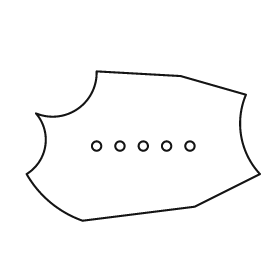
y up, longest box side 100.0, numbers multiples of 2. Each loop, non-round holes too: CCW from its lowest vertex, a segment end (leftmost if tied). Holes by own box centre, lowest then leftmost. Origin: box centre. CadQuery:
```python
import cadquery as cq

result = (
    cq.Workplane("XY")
    .moveTo(-26.0, -32.0)
    .lineTo(22.0, -26.0)
    .lineTo(50.0, -12.0)
    .threePointArc((42.0, 4.0), (44.0, 22.0))
    .lineTo(16.0, 30.0)
    .lineTo(-20.0, 32.0)
    .threePointArc((-28.0, 16.0), (-46.0, 14.0))
    .threePointArc((-42.0, 0.0), (-50.0, -12.0))
    .threePointArc((-40.0, -24.0), (-26.0, -32.0))
    .close()
    .moveTo(-20.0, 0.0)
    .circle(2.0)
    .moveTo(-10.0, 0.0)
    .circle(2.0)
    .moveTo(0.0, 0.0)
    .circle(2.0)
    .moveTo(10.0, 0.0)
    .circle(2.0)
    .moveTo(20.0, 0.0)
    .circle(2.0)
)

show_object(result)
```